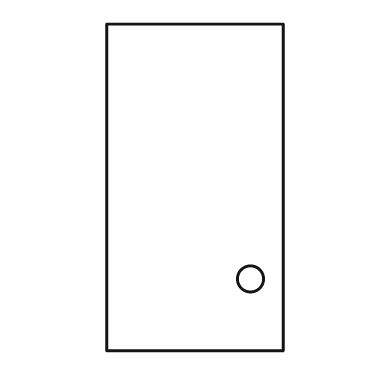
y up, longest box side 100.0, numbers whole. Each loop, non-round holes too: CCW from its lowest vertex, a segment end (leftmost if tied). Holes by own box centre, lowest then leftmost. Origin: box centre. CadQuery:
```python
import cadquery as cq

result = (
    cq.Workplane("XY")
    .moveTo(-27.0, -50.0)
    .lineTo(27.0, -50.0)
    .lineTo(27.0, 50.0)
    .lineTo(-27.0, 50.0)
    .close()
    .moveTo(17.0, -28.0)
    .circle(4.0)
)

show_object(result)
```